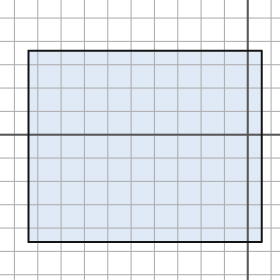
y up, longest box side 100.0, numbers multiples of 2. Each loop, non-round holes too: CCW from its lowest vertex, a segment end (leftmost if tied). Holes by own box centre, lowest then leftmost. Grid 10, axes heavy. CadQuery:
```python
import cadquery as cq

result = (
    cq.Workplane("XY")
    .moveTo(-94.0, -46.0)
    .lineTo(6.0, -46.0)
    .lineTo(6.0, 36.0)
    .lineTo(-94.0, 36.0)
    .close()
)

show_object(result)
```